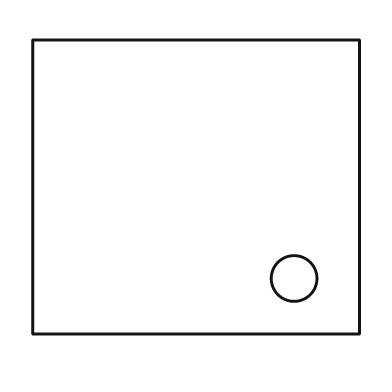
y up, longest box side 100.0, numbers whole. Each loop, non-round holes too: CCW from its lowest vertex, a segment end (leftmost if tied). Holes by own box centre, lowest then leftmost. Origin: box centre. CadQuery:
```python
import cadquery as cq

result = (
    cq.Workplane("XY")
    .moveTo(-50.0, -45.0)
    .lineTo(50.0, -45.0)
    .lineTo(50.0, 45.0)
    .lineTo(-50.0, 45.0)
    .close()
    .moveTo(30.0, -28.0)
    .circle(7.0)
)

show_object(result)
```